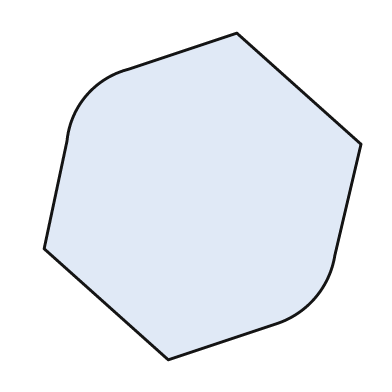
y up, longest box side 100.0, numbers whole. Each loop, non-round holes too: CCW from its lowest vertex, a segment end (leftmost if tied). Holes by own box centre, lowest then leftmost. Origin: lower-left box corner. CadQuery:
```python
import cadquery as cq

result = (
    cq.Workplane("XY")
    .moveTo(38.0, 0.0)
    .lineTo(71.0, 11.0)
    .threePointArc((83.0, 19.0), (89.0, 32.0))
    .lineTo(97.0, 66.0)
    .lineTo(59.0, 100.0)
    .lineTo(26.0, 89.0)
    .threePointArc((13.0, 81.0), (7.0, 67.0))
    .lineTo(0.0, 34.0)
    .close()
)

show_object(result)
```